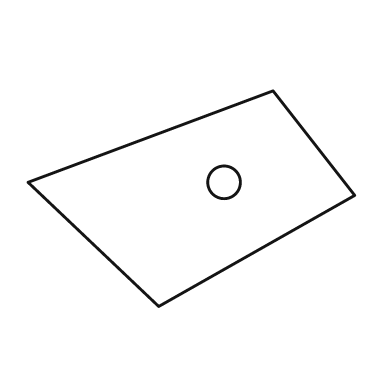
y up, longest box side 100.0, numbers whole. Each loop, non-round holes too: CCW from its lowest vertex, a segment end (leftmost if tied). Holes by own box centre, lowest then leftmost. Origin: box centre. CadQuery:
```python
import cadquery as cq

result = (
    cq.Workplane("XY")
    .moveTo(-10.0, -33.0)
    .lineTo(50.0, 1.0)
    .lineTo(25.0, 33.0)
    .lineTo(-50.0, 5.0)
    .close()
    .moveTo(10.0, 5.0)
    .circle(5.0)
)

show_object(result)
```